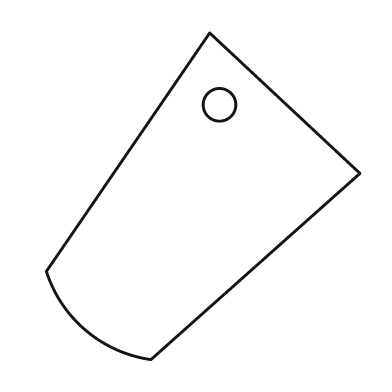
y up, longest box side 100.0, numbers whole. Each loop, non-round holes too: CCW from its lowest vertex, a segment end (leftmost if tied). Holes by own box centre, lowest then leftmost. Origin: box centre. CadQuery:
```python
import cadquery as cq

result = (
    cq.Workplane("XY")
    .moveTo(-16.0, -50.0)
    .lineTo(48.0, 7.0)
    .lineTo(2.0, 50.0)
    .lineTo(-48.0, -23.0)
    .threePointArc((-36.0, -41.0), (-16.0, -50.0))
    .close()
    .moveTo(5.0, 28.0)
    .circle(5.0)
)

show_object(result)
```